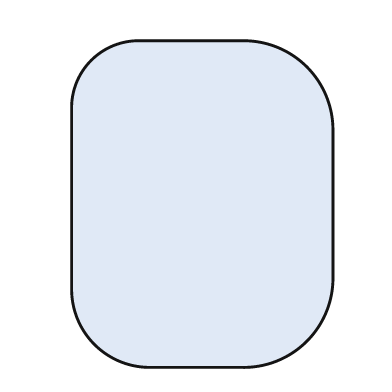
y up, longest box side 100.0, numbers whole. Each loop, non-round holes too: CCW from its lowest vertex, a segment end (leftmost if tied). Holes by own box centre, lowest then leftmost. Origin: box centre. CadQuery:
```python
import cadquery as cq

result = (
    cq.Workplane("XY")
    .moveTo(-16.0, -50.0)
    .lineTo(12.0, -50.0)
    .threePointArc((32.0, -42.0), (40.0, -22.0))
    .lineTo(40.0, 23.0)
    .threePointArc((32.0, 42.0), (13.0, 50.0))
    .lineTo(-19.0, 50.0)
    .threePointArc((-34.0, 44.0), (-40.0, 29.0))
    .lineTo(-40.0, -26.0)
    .threePointArc((-33.0, -43.0), (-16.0, -50.0))
    .close()
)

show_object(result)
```